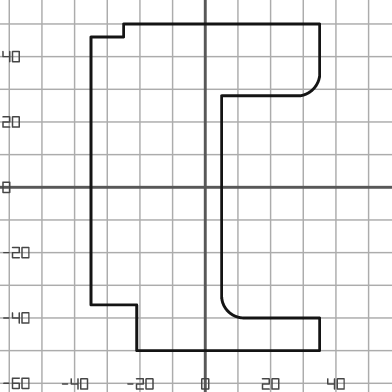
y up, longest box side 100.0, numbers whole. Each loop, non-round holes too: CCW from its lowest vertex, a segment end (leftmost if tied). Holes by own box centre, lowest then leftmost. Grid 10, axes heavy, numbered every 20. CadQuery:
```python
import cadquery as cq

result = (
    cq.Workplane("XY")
    .moveTo(-21.0, -50.0)
    .lineTo(35.0, -50.0)
    .lineTo(35.0, -40.0)
    .lineTo(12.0, -40.0)
    .threePointArc((7.0, -38.0), (5.0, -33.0))
    .lineTo(5.0, 28.0)
    .lineTo(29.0, 28.0)
    .threePointArc((33.0, 30.0), (35.0, 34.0))
    .lineTo(35.0, 50.0)
    .lineTo(-25.0, 50.0)
    .lineTo(-25.0, 46.0)
    .lineTo(-35.0, 46.0)
    .lineTo(-35.0, -36.0)
    .lineTo(-21.0, -36.0)
    .close()
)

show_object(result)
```